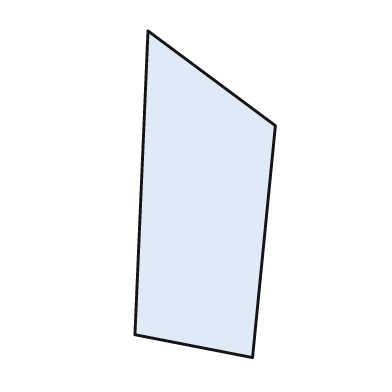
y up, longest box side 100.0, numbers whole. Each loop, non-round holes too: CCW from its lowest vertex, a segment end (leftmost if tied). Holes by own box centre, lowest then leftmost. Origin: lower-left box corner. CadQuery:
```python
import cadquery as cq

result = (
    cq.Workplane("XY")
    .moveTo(36.0, 0.0)
    .lineTo(43.0, 71.0)
    .lineTo(4.0, 100.0)
    .lineTo(0.0, 7.0)
    .close()
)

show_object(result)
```